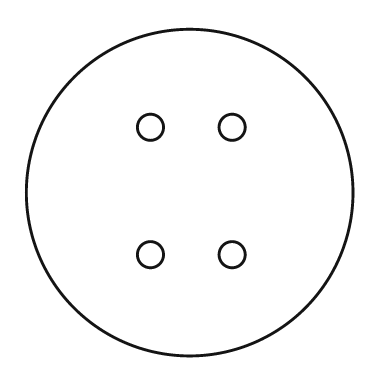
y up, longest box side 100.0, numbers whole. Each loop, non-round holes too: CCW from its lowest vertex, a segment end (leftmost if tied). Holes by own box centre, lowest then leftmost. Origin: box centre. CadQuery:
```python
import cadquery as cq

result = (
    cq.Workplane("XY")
    .moveTo(0.0, 0.0)
    .circle(50.0)
    .moveTo(-12.0, -19.0)
    .circle(4.0)
    .moveTo(13.0, -19.0)
    .circle(4.0)
    .moveTo(-12.0, 20.0)
    .circle(4.0)
    .moveTo(13.0, 20.0)
    .circle(4.0)
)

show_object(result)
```